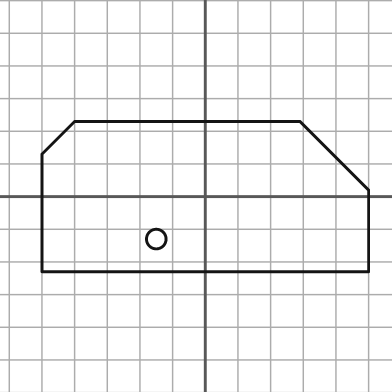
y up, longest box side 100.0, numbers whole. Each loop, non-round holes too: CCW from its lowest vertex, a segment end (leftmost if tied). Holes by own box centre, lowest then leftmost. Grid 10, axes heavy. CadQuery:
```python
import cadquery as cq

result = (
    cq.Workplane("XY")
    .moveTo(-50.0, -23.0)
    .lineTo(50.0, -23.0)
    .lineTo(50.0, 2.0)
    .lineTo(29.0, 23.0)
    .lineTo(-40.0, 23.0)
    .lineTo(-50.0, 13.0)
    .close()
    .moveTo(-15.0, -13.0)
    .circle(3.0)
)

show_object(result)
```